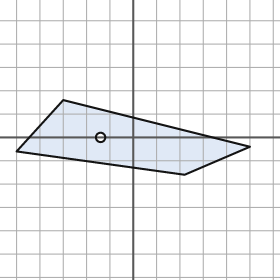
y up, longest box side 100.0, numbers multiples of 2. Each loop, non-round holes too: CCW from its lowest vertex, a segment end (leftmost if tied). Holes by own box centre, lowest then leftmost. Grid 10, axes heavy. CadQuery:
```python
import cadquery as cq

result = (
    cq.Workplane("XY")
    .moveTo(22.0, -16.0)
    .lineTo(50.0, -4.0)
    .lineTo(-30.0, 16.0)
    .lineTo(-50.0, -6.0)
    .close()
    .moveTo(-14.0, 0.0)
    .circle(2.0)
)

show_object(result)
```